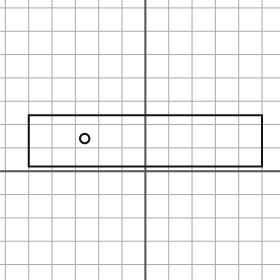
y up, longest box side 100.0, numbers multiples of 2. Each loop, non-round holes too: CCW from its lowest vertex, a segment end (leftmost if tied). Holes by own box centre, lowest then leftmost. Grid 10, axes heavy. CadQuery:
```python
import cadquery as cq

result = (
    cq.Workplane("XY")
    .moveTo(-50.0, 2.0)
    .lineTo(50.0, 2.0)
    .lineTo(50.0, 24.0)
    .lineTo(-50.0, 24.0)
    .close()
    .moveTo(-26.0, 14.0)
    .circle(2.0)
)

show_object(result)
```